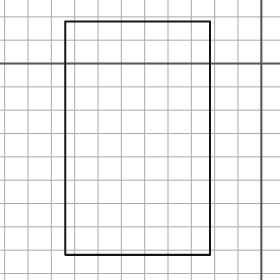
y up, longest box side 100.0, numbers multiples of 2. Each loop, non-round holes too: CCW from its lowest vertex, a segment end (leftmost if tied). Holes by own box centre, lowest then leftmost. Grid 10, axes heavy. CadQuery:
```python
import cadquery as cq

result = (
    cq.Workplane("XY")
    .moveTo(-84.0, -82.0)
    .lineTo(-22.0, -82.0)
    .lineTo(-22.0, 18.0)
    .lineTo(-84.0, 18.0)
    .close()
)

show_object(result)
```